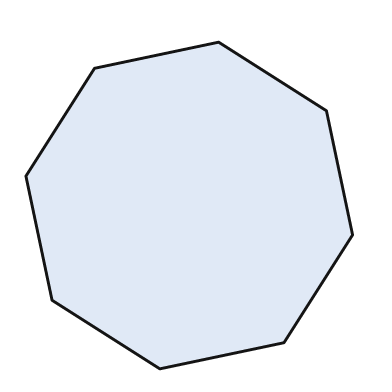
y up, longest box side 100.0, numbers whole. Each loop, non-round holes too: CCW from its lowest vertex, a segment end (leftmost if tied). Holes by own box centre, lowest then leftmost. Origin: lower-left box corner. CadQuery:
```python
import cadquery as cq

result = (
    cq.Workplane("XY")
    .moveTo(41.0, 0.0)
    .lineTo(79.0, 8.0)
    .lineTo(100.0, 41.0)
    .lineTo(92.0, 79.0)
    .lineTo(59.0, 100.0)
    .lineTo(21.0, 92.0)
    .lineTo(0.0, 59.0)
    .lineTo(8.0, 21.0)
    .close()
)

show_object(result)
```